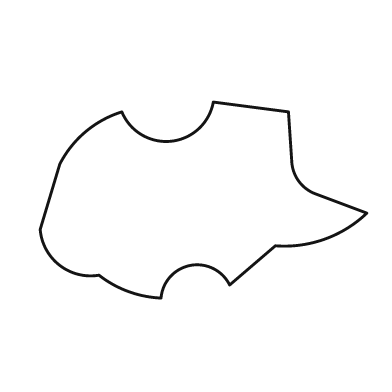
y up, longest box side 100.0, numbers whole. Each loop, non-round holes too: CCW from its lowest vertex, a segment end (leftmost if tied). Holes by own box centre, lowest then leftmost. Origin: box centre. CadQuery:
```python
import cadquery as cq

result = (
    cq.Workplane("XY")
    .moveTo(-13.0, -30.0)
    .threePointArc((-4.0, -20.0), (8.0, -26.0))
    .lineTo(22.0, -14.0)
    .threePointArc((37.0, -12.0), (50.0, -4.0))
    .lineTo(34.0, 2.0)
    .threePointArc((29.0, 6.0), (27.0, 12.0))
    .lineTo(26.0, 27.0)
    .lineTo(3.0, 30.0)
    .threePointArc((-10.0, 18.0), (-25.0, 27.0))
    .threePointArc((-36.0, 21.0), (-44.0, 11.0))
    .lineTo(-50.0, -9.0)
    .threePointArc((-44.0, -20.0), (-32.0, -23.0))
    .threePointArc((-23.0, -28.0), (-13.0, -30.0))
    .close()
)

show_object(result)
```